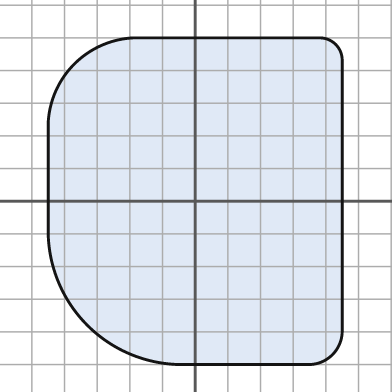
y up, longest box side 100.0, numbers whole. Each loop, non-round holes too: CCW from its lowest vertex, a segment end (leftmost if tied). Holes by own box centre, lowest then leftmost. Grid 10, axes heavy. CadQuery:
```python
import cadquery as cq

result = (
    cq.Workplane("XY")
    .moveTo(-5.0, -50.0)
    .lineTo(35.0, -50.0)
    .threePointArc((42.0, -47.0), (45.0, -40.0))
    .lineTo(45.0, 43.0)
    .threePointArc((43.0, 48.0), (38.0, 50.0))
    .lineTo(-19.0, 50.0)
    .threePointArc((-37.0, 42.0), (-45.0, 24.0))
    .lineTo(-45.0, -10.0)
    .threePointArc((-33.0, -38.0), (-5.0, -50.0))
    .close()
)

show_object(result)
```